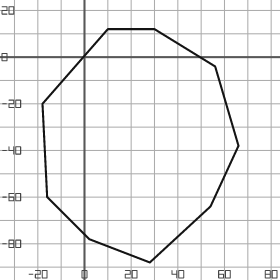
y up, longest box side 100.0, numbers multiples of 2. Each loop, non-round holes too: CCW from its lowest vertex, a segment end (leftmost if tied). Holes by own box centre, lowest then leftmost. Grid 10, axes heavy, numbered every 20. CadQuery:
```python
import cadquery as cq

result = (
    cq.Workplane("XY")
    .moveTo(28.0, -88.0)
    .lineTo(54.0, -64.0)
    .lineTo(66.0, -38.0)
    .lineTo(56.0, -4.0)
    .lineTo(30.0, 12.0)
    .lineTo(10.0, 12.0)
    .lineTo(-18.0, -20.0)
    .lineTo(-16.0, -60.0)
    .lineTo(2.0, -78.0)
    .close()
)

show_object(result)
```